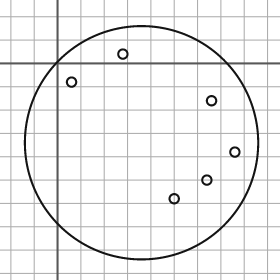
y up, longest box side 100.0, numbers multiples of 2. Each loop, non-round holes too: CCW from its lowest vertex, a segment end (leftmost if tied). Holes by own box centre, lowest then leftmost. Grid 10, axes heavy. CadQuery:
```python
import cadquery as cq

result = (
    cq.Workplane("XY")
    .moveTo(36.0, -34.0)
    .circle(50.0)
    .moveTo(50.0, -58.0)
    .circle(2.0)
    .moveTo(64.0, -50.0)
    .circle(2.0)
    .moveTo(76.0, -38.0)
    .circle(2.0)
    .moveTo(66.0, -16.0)
    .circle(2.0)
    .moveTo(6.0, -8.0)
    .circle(2.0)
    .moveTo(28.0, 4.0)
    .circle(2.0)
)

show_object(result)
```